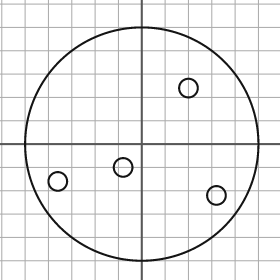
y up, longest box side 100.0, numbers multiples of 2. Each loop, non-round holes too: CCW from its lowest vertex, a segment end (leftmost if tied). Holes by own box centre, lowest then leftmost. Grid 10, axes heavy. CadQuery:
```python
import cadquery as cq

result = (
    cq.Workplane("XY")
    .moveTo(0.0, 0.0)
    .circle(50.0)
    .moveTo(32.0, -22.0)
    .circle(4.0)
    .moveTo(-36.0, -16.0)
    .circle(4.0)
    .moveTo(-8.0, -10.0)
    .circle(4.0)
    .moveTo(20.0, 24.0)
    .circle(4.0)
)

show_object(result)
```